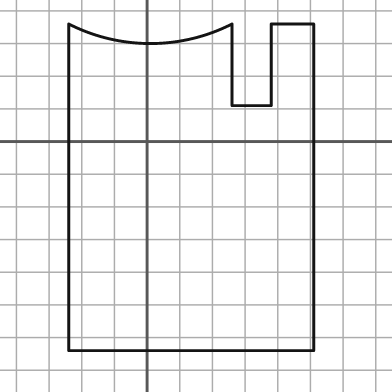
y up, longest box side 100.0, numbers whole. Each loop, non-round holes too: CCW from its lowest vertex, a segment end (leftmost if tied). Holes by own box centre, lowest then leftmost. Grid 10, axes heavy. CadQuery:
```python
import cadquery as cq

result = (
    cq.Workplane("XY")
    .moveTo(-24.0, -64.0)
    .lineTo(51.0, -64.0)
    .lineTo(51.0, 36.0)
    .lineTo(38.0, 36.0)
    .lineTo(38.0, 11.0)
    .lineTo(26.0, 11.0)
    .lineTo(26.0, 36.0)
    .threePointArc((1.0, 30.0), (-24.0, 36.0))
    .close()
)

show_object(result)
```